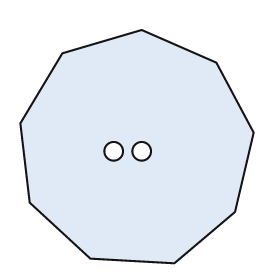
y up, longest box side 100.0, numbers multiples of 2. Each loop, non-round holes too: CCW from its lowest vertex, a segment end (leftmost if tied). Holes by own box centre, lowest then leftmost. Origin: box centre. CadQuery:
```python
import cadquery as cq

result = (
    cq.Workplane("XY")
    .moveTo(16.0, -50.0)
    .lineTo(42.0, -28.0)
    .lineTo(50.0, 6.0)
    .lineTo(34.0, 36.0)
    .lineTo(2.0, 50.0)
    .lineTo(-32.0, 40.0)
    .lineTo(-50.0, 10.0)
    .lineTo(-46.0, -24.0)
    .lineTo(-20.0, -48.0)
    .close()
    .moveTo(-10.0, -2.0)
    .circle(4.0)
    .moveTo(2.0, -2.0)
    .circle(4.0)
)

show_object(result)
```